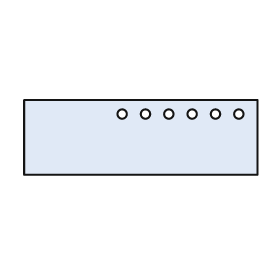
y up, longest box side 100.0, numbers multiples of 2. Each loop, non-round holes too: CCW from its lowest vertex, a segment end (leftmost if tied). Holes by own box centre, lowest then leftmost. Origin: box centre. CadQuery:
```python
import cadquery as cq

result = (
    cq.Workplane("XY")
    .moveTo(-50.0, -16.0)
    .lineTo(50.0, -16.0)
    .lineTo(50.0, 16.0)
    .lineTo(-50.0, 16.0)
    .close()
    .moveTo(-8.0, 10.0)
    .circle(2.0)
    .moveTo(2.0, 10.0)
    .circle(2.0)
    .moveTo(12.0, 10.0)
    .circle(2.0)
    .moveTo(22.0, 10.0)
    .circle(2.0)
    .moveTo(32.0, 10.0)
    .circle(2.0)
    .moveTo(42.0, 10.0)
    .circle(2.0)
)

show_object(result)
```